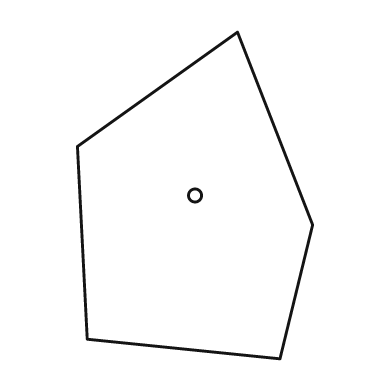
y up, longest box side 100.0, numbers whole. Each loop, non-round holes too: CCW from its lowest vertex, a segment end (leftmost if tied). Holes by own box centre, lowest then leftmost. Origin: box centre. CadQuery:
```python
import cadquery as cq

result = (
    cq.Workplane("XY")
    .moveTo(26.0, -50.0)
    .lineTo(36.0, -9.0)
    .lineTo(13.0, 50.0)
    .lineTo(-36.0, 15.0)
    .lineTo(-33.0, -44.0)
    .close()
    .moveTo(0.0, 0.0)
    .circle(2.0)
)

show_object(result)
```